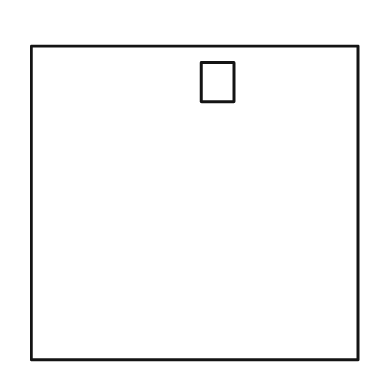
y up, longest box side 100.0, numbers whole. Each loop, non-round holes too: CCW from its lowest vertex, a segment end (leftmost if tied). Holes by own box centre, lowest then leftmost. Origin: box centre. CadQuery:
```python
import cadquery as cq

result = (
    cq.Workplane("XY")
    .moveTo(-50.0, -48.0)
    .lineTo(50.0, -48.0)
    .lineTo(50.0, 48.0)
    .lineTo(-50.0, 48.0)
    .close()
    .moveTo(2.0, 31.0)
    .lineTo(12.0, 31.0)
    .lineTo(12.0, 43.0)
    .lineTo(2.0, 43.0)
    .close()
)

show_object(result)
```